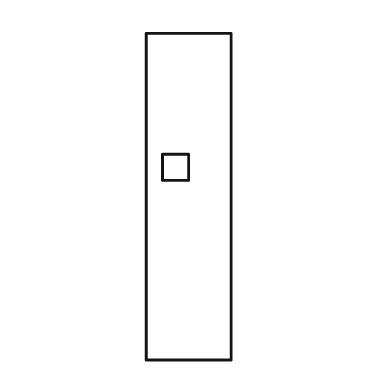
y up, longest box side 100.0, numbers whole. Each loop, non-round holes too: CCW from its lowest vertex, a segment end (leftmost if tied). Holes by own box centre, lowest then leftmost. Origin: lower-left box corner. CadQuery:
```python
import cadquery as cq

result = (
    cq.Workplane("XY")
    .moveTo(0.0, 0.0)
    .lineTo(26.0, 0.0)
    .lineTo(26.0, 100.0)
    .lineTo(0.0, 100.0)
    .close()
    .moveTo(5.0, 55.0)
    .lineTo(13.0, 55.0)
    .lineTo(13.0, 63.0)
    .lineTo(5.0, 63.0)
    .close()
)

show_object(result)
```